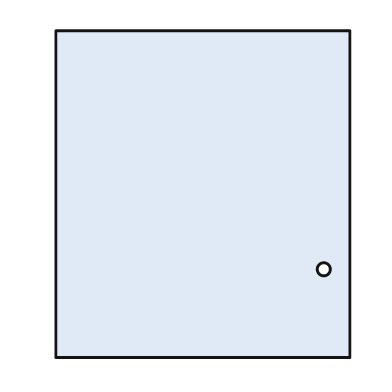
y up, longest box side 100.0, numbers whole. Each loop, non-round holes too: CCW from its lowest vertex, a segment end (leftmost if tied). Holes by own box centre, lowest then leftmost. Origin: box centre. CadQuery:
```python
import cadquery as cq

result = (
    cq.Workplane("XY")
    .moveTo(-45.0, -50.0)
    .lineTo(45.0, -50.0)
    .lineTo(45.0, 50.0)
    .lineTo(-45.0, 50.0)
    .close()
    .moveTo(37.0, -23.0)
    .circle(2.0)
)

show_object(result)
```